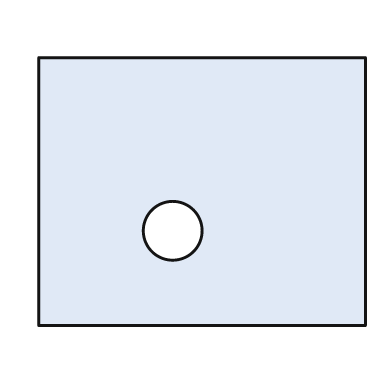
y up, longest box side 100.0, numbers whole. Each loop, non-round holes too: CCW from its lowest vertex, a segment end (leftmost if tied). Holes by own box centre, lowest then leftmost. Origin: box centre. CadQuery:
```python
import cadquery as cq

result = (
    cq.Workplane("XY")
    .moveTo(-50.0, -41.0)
    .lineTo(50.0, -41.0)
    .lineTo(50.0, 41.0)
    .lineTo(-50.0, 41.0)
    .close()
    .moveTo(-9.0, -12.0)
    .circle(9.0)
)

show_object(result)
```